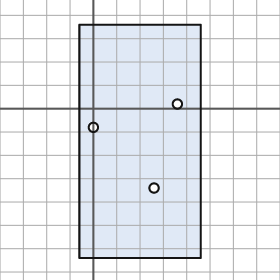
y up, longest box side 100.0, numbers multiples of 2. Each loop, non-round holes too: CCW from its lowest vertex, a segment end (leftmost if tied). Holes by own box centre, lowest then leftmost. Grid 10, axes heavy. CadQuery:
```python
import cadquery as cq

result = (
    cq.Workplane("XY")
    .moveTo(-6.0, -64.0)
    .lineTo(46.0, -64.0)
    .lineTo(46.0, 36.0)
    .lineTo(-6.0, 36.0)
    .close()
    .moveTo(26.0, -34.0)
    .circle(2.0)
    .moveTo(0.0, -8.0)
    .circle(2.0)
    .moveTo(36.0, 2.0)
    .circle(2.0)
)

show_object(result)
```